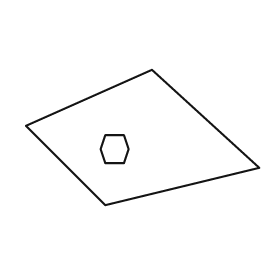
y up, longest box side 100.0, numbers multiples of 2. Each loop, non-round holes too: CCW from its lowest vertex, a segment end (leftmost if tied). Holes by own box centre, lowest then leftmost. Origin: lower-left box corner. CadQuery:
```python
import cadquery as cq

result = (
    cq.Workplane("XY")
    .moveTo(34.0, 0.0)
    .lineTo(100.0, 16.0)
    .lineTo(54.0, 58.0)
    .lineTo(0.0, 34.0)
    .close()
    .moveTo(34.0, 18.0)
    .lineTo(42.0, 18.0)
    .lineTo(44.0, 24.0)
    .lineTo(42.0, 30.0)
    .lineTo(34.0, 30.0)
    .lineTo(32.0, 24.0)
    .close()
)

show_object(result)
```